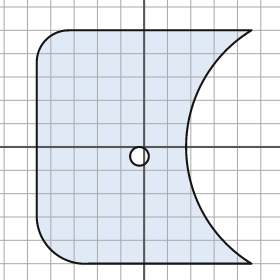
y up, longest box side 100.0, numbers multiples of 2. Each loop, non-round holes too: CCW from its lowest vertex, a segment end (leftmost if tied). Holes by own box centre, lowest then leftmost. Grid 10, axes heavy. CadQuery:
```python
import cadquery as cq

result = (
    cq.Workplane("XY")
    .moveTo(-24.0, -50.0)
    .lineTo(46.0, -50.0)
    .threePointArc((18.0, 0.0), (46.0, 50.0))
    .lineTo(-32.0, 50.0)
    .threePointArc((-42.0, 46.0), (-46.0, 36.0))
    .lineTo(-46.0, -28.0)
    .threePointArc((-40.0, -44.0), (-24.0, -50.0))
    .close()
    .moveTo(-2.0, -4.0)
    .circle(4.0)
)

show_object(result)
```